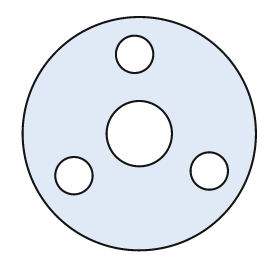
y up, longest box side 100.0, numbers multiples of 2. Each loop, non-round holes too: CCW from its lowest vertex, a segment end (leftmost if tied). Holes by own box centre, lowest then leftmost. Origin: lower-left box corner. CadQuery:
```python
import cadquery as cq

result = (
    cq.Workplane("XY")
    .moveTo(50.0, 50.0)
    .circle(50.0)
    .moveTo(22.0, 32.0)
    .circle(8.0)
    .moveTo(80.0, 34.0)
    .circle(8.0)
    .moveTo(50.0, 50.0)
    .circle(14.0)
    .moveTo(48.0, 84.0)
    .circle(8.0)
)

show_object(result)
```